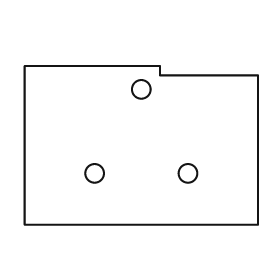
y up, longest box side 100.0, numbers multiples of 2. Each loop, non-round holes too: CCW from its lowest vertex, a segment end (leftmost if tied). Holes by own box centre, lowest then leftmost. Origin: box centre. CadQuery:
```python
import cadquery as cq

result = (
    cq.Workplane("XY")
    .moveTo(-50.0, -34.0)
    .lineTo(50.0, -34.0)
    .lineTo(50.0, 30.0)
    .lineTo(8.0, 30.0)
    .lineTo(8.0, 34.0)
    .lineTo(-50.0, 34.0)
    .close()
    .moveTo(-20.0, -12.0)
    .circle(4.0)
    .moveTo(20.0, -12.0)
    .circle(4.0)
    .moveTo(0.0, 24.0)
    .circle(4.0)
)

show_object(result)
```